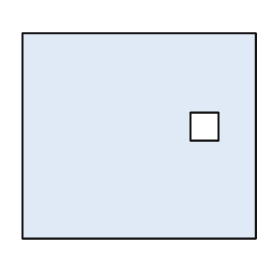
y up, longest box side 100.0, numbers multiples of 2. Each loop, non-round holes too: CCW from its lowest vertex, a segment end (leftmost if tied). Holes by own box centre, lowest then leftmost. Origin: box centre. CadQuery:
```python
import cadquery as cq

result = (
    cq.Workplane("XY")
    .moveTo(-50.0, -44.0)
    .lineTo(50.0, -44.0)
    .lineTo(50.0, 44.0)
    .lineTo(-50.0, 44.0)
    .close()
    .moveTo(22.0, -2.0)
    .lineTo(34.0, -2.0)
    .lineTo(34.0, 10.0)
    .lineTo(22.0, 10.0)
    .close()
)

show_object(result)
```